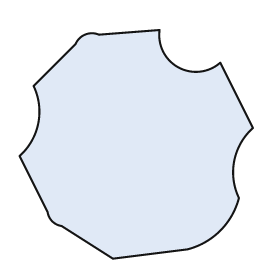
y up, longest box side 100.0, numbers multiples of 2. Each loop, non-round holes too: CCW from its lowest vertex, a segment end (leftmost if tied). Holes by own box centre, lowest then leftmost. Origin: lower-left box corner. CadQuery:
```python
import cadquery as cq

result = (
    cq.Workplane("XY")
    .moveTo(40.0, 0.0)
    .lineTo(72.0, 4.0)
    .threePointArc((86.0, 12.0), (94.0, 26.0))
    .threePointArc((92.0, 42.0), (100.0, 56.0))
    .lineTo(86.0, 84.0)
    .threePointArc((68.0, 82.0), (60.0, 98.0))
    .lineTo(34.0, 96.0)
    .threePointArc((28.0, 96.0), (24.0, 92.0))
    .lineTo(6.0, 74.0)
    .threePointArc((8.0, 58.0), (0.0, 44.0))
    .lineTo(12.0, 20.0)
    .threePointArc((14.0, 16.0), (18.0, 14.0))
    .close()
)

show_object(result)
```